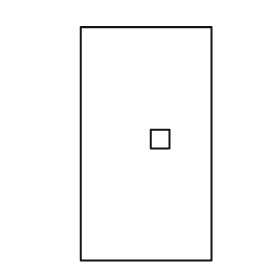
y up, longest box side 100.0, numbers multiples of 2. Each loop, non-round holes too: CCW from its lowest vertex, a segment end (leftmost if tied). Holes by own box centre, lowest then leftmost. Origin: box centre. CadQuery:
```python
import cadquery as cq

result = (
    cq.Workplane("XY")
    .moveTo(-28.0, -50.0)
    .lineTo(28.0, -50.0)
    .lineTo(28.0, 50.0)
    .lineTo(-28.0, 50.0)
    .close()
    .moveTo(2.0, -2.0)
    .lineTo(10.0, -2.0)
    .lineTo(10.0, 6.0)
    .lineTo(2.0, 6.0)
    .close()
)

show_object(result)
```